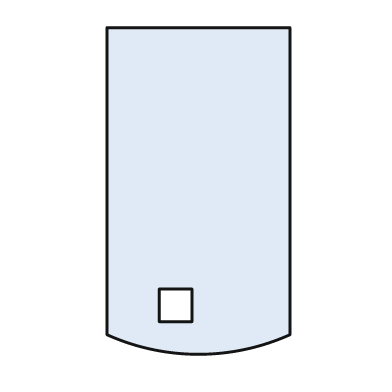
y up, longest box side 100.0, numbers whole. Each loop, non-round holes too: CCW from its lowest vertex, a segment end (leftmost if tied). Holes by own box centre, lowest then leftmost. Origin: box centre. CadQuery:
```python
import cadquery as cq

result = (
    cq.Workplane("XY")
    .moveTo(-28.0, -44.0)
    .threePointArc((0.0, -50.0), (28.0, -44.0))
    .lineTo(28.0, 50.0)
    .lineTo(-28.0, 50.0)
    .close()
    .moveTo(-12.0, -40.0)
    .lineTo(-2.0, -40.0)
    .lineTo(-2.0, -30.0)
    .lineTo(-12.0, -30.0)
    .close()
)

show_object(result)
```